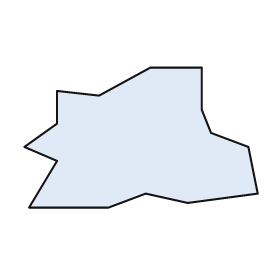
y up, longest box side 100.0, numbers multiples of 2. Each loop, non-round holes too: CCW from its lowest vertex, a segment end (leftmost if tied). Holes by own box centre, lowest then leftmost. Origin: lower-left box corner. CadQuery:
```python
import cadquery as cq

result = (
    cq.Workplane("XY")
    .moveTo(2.0, 0.0)
    .lineTo(36.0, 0.0)
    .lineTo(52.0, 6.0)
    .lineTo(70.0, 2.0)
    .lineTo(100.0, 6.0)
    .lineTo(96.0, 26.0)
    .lineTo(80.0, 32.0)
    .lineTo(76.0, 42.0)
    .lineTo(76.0, 60.0)
    .lineTo(54.0, 60.0)
    .lineTo(32.0, 48.0)
    .lineTo(14.0, 50.0)
    .lineTo(14.0, 36.0)
    .lineTo(0.0, 26.0)
    .lineTo(14.0, 20.0)
    .close()
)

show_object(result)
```